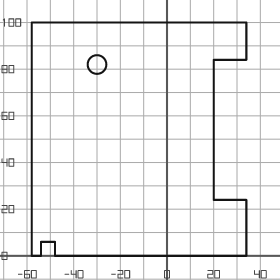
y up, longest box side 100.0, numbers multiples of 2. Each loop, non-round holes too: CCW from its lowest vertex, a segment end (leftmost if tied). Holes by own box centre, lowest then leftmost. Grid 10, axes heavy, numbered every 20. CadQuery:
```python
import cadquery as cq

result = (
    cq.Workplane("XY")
    .moveTo(-58.0, 0.0)
    .lineTo(-54.0, 0.0)
    .lineTo(-54.0, 6.0)
    .lineTo(-48.0, 6.0)
    .lineTo(-48.0, 0.0)
    .lineTo(34.0, 0.0)
    .lineTo(34.0, 24.0)
    .lineTo(20.0, 24.0)
    .lineTo(20.0, 84.0)
    .lineTo(34.0, 84.0)
    .lineTo(34.0, 100.0)
    .lineTo(-58.0, 100.0)
    .close()
    .moveTo(-30.0, 82.0)
    .circle(4.0)
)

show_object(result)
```